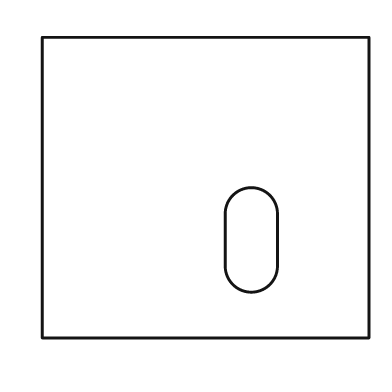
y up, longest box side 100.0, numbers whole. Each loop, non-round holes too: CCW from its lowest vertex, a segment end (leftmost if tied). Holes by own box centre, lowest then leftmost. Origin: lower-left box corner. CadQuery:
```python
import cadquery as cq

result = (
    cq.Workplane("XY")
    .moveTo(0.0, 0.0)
    .lineTo(100.0, 0.0)
    .lineTo(100.0, 92.0)
    .lineTo(0.0, 92.0)
    .close()
    .moveTo(56.0, 22.0)
    .threePointArc((64.0, 14.0), (72.0, 22.0))
    .lineTo(72.0, 38.0)
    .threePointArc((64.0, 46.0), (56.0, 38.0))
    .close()
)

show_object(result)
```